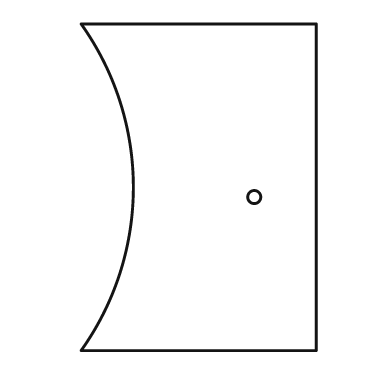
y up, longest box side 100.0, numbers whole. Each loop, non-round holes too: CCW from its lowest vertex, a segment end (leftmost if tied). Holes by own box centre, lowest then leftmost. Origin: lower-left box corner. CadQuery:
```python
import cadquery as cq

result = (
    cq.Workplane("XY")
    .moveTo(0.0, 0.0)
    .lineTo(72.0, 0.0)
    .lineTo(72.0, 100.0)
    .lineTo(0.0, 100.0)
    .threePointArc((16.0, 50.0), (0.0, 0.0))
    .close()
    .moveTo(53.0, 47.0)
    .circle(2.0)
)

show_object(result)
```